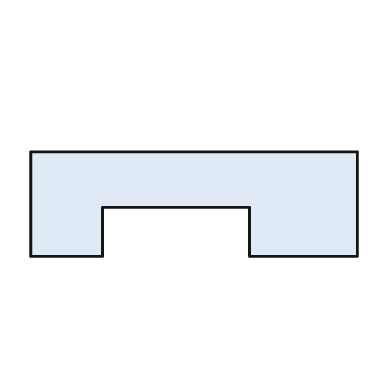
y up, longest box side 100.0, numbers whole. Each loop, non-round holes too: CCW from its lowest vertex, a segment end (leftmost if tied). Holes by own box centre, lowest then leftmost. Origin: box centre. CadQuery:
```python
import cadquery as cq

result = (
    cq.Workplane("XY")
    .moveTo(-50.0, -16.0)
    .lineTo(-28.0, -16.0)
    .lineTo(-28.0, -1.0)
    .lineTo(17.0, -1.0)
    .lineTo(17.0, -16.0)
    .lineTo(50.0, -16.0)
    .lineTo(50.0, 16.0)
    .lineTo(-50.0, 16.0)
    .close()
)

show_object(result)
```